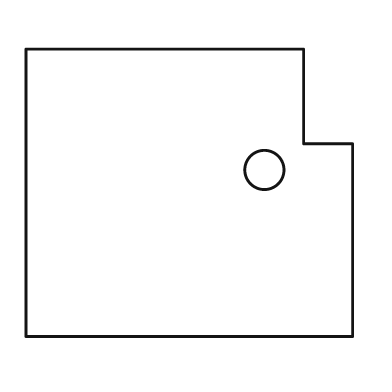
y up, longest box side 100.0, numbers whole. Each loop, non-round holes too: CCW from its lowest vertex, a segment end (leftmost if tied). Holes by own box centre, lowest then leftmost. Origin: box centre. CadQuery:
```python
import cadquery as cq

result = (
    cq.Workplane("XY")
    .moveTo(-50.0, -44.0)
    .lineTo(50.0, -44.0)
    .lineTo(50.0, 15.0)
    .lineTo(35.0, 15.0)
    .lineTo(35.0, 44.0)
    .lineTo(-50.0, 44.0)
    .close()
    .moveTo(23.0, 7.0)
    .circle(6.0)
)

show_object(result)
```